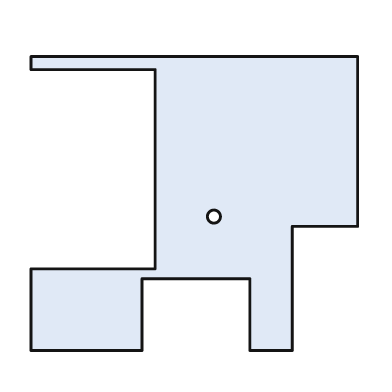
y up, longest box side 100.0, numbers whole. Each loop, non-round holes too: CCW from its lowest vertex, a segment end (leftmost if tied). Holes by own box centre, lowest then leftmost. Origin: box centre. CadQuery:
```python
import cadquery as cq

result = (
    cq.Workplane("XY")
    .moveTo(-50.0, -45.0)
    .lineTo(-16.0, -45.0)
    .lineTo(-16.0, -23.0)
    .lineTo(17.0, -23.0)
    .lineTo(17.0, -45.0)
    .lineTo(30.0, -45.0)
    .lineTo(30.0, -7.0)
    .lineTo(50.0, -7.0)
    .lineTo(50.0, 45.0)
    .lineTo(-50.0, 45.0)
    .lineTo(-50.0, 41.0)
    .lineTo(-12.0, 41.0)
    .lineTo(-12.0, -20.0)
    .lineTo(-50.0, -20.0)
    .close()
    .moveTo(6.0, -4.0)
    .circle(2.0)
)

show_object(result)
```